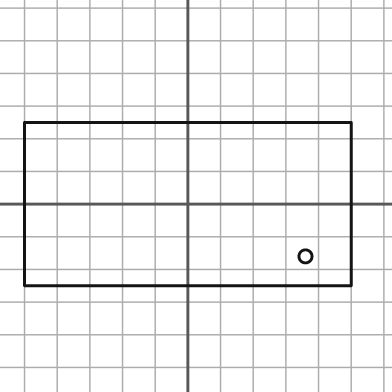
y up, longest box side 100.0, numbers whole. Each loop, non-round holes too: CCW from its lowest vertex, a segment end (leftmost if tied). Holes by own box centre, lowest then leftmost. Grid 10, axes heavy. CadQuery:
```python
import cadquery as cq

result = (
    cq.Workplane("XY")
    .moveTo(-50.0, -25.0)
    .lineTo(50.0, -25.0)
    .lineTo(50.0, 25.0)
    .lineTo(-50.0, 25.0)
    .close()
    .moveTo(36.0, -16.0)
    .circle(2.0)
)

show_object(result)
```